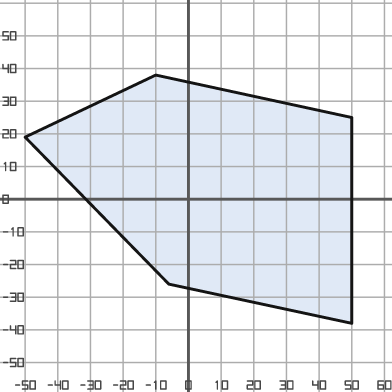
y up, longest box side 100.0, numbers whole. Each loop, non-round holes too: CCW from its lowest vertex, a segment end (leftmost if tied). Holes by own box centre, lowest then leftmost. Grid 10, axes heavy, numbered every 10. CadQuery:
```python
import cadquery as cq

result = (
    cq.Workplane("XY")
    .moveTo(50.0, -38.0)
    .lineTo(50.0, 25.0)
    .lineTo(-10.0, 38.0)
    .lineTo(-50.0, 19.0)
    .lineTo(-6.0, -26.0)
    .close()
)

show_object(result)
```